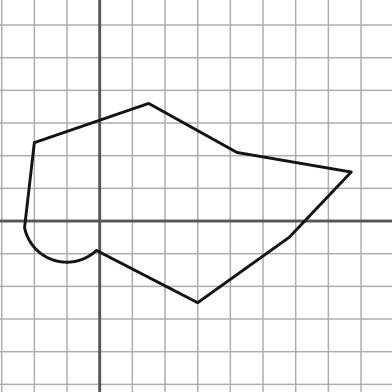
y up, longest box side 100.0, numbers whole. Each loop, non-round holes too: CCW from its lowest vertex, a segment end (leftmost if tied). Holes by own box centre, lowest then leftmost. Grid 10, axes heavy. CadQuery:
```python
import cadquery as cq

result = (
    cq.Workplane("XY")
    .moveTo(30.0, -25.0)
    .lineTo(58.0, -5.0)
    .lineTo(77.0, 15.0)
    .lineTo(42.0, 21.0)
    .lineTo(15.0, 36.0)
    .lineTo(-20.0, 24.0)
    .lineTo(-23.0, -2.0)
    .threePointArc((-14.0, -12.0), (-1.0, -9.0))
    .close()
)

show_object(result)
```